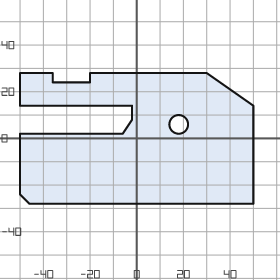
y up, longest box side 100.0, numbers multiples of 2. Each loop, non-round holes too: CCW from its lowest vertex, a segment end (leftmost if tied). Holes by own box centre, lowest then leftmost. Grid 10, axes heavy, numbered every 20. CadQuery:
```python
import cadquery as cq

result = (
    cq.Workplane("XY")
    .moveTo(-46.0, -28.0)
    .lineTo(50.0, -28.0)
    .lineTo(50.0, 14.0)
    .lineTo(30.0, 28.0)
    .lineTo(-20.0, 28.0)
    .lineTo(-20.0, 24.0)
    .lineTo(-36.0, 24.0)
    .lineTo(-36.0, 28.0)
    .lineTo(-50.0, 28.0)
    .lineTo(-50.0, 14.0)
    .lineTo(-2.0, 14.0)
    .lineTo(-2.0, 8.0)
    .lineTo(-6.0, 2.0)
    .lineTo(-50.0, 2.0)
    .lineTo(-50.0, -24.0)
    .close()
    .moveTo(18.0, 6.0)
    .circle(4.0)
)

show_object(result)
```